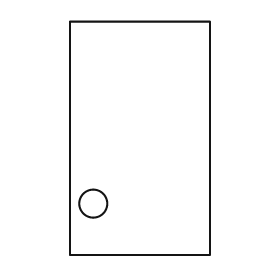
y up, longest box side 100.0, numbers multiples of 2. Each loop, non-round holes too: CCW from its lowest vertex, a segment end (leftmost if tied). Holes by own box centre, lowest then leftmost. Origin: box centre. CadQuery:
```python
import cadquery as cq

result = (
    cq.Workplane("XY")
    .moveTo(-30.0, -50.0)
    .lineTo(30.0, -50.0)
    .lineTo(30.0, 50.0)
    .lineTo(-30.0, 50.0)
    .close()
    .moveTo(-20.0, -28.0)
    .circle(6.0)
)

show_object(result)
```